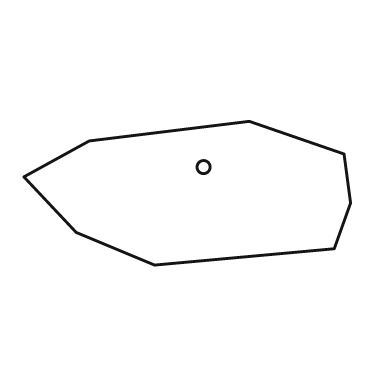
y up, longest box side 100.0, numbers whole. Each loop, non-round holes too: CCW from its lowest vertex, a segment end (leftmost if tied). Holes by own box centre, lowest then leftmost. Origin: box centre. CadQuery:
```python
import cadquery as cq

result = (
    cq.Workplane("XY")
    .moveTo(-10.0, -22.0)
    .lineTo(45.0, -17.0)
    .lineTo(50.0, -3.0)
    .lineTo(48.0, 12.0)
    .lineTo(19.0, 22.0)
    .lineTo(-30.0, 16.0)
    .lineTo(-50.0, 5.0)
    .lineTo(-34.0, -12.0)
    .close()
    .moveTo(5.0, 8.0)
    .circle(2.0)
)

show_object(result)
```